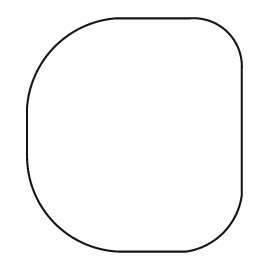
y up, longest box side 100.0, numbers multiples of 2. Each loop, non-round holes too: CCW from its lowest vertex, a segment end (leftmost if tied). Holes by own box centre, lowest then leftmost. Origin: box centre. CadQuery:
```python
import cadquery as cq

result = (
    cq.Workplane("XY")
    .moveTo(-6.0, -50.0)
    .lineTo(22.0, -50.0)
    .threePointArc((38.0, -42.0), (46.0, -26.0))
    .lineTo(46.0, 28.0)
    .threePointArc((40.0, 44.0), (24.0, 50.0))
    .lineTo(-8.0, 50.0)
    .threePointArc((-34.0, 38.0), (-46.0, 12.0))
    .lineTo(-46.0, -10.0)
    .threePointArc((-34.0, -38.0), (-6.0, -50.0))
    .close()
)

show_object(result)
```